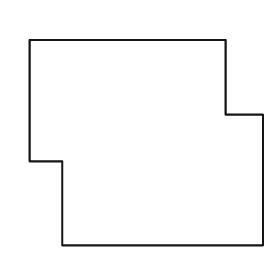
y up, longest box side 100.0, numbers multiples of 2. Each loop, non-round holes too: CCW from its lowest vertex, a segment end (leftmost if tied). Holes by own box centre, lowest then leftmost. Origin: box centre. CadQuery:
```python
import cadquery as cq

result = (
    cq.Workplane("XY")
    .moveTo(-36.0, -44.0)
    .lineTo(50.0, -44.0)
    .lineTo(50.0, 12.0)
    .lineTo(34.0, 12.0)
    .lineTo(34.0, 44.0)
    .lineTo(-50.0, 44.0)
    .lineTo(-50.0, -8.0)
    .lineTo(-36.0, -8.0)
    .close()
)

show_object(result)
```